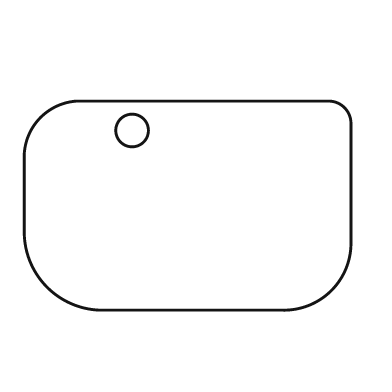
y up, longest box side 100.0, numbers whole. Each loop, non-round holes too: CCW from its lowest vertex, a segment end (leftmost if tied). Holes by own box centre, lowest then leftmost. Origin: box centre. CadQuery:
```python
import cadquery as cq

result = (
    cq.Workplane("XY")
    .moveTo(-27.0, -32.0)
    .lineTo(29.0, -32.0)
    .threePointArc((44.0, -26.0), (50.0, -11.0))
    .lineTo(50.0, 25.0)
    .threePointArc((48.0, 30.0), (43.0, 32.0))
    .lineTo(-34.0, 32.0)
    .threePointArc((-45.0, 27.0), (-50.0, 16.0))
    .lineTo(-50.0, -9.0)
    .threePointArc((-43.0, -25.0), (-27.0, -32.0))
    .close()
    .moveTo(-17.0, 23.0)
    .circle(5.0)
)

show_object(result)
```